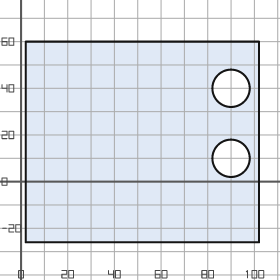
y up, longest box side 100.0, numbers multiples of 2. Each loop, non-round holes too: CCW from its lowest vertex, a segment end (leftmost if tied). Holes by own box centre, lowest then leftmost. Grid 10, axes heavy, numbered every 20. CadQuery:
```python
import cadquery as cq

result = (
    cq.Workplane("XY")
    .moveTo(2.0, -26.0)
    .lineTo(102.0, -26.0)
    .lineTo(102.0, 60.0)
    .lineTo(2.0, 60.0)
    .close()
    .moveTo(90.0, 10.0)
    .circle(8.0)
    .moveTo(90.0, 40.0)
    .circle(8.0)
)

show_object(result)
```